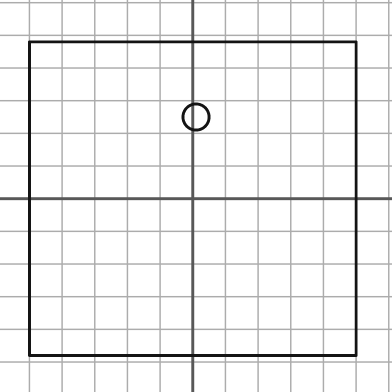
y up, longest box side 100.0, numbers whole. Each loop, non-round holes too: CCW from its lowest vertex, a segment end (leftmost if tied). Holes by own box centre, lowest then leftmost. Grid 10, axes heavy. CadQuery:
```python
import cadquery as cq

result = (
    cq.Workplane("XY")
    .moveTo(-50.0, -48.0)
    .lineTo(50.0, -48.0)
    .lineTo(50.0, 48.0)
    .lineTo(-50.0, 48.0)
    .close()
    .moveTo(1.0, 25.0)
    .circle(4.0)
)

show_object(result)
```